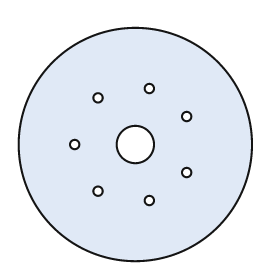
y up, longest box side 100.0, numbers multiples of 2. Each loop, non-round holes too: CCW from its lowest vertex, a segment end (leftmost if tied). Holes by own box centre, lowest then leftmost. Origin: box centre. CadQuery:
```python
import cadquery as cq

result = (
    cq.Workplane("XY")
    .moveTo(0.0, 0.0)
    .circle(50.0)
    .moveTo(6.0, -24.0)
    .circle(2.0)
    .moveTo(-16.0, -20.0)
    .circle(2.0)
    .moveTo(22.0, -12.0)
    .circle(2.0)
    .moveTo(-26.0, 0.0)
    .circle(2.0)
    .moveTo(0.0, 0.0)
    .circle(8.0)
    .moveTo(22.0, 12.0)
    .circle(2.0)
    .moveTo(-16.0, 20.0)
    .circle(2.0)
    .moveTo(6.0, 24.0)
    .circle(2.0)
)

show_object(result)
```